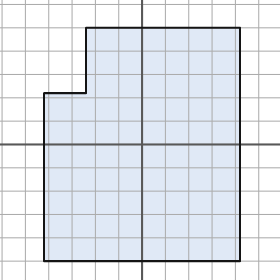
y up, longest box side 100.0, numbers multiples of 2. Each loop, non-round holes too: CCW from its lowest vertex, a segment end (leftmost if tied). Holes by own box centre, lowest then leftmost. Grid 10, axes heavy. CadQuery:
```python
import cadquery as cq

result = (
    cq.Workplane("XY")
    .moveTo(-42.0, -50.0)
    .lineTo(42.0, -50.0)
    .lineTo(42.0, 50.0)
    .lineTo(-24.0, 50.0)
    .lineTo(-24.0, 22.0)
    .lineTo(-42.0, 22.0)
    .close()
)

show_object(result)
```